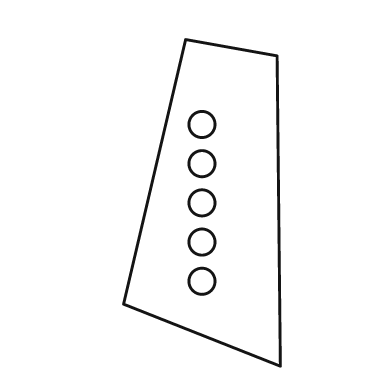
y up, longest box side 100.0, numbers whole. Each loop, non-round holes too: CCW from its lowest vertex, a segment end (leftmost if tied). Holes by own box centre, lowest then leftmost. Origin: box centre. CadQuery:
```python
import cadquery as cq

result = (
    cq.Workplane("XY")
    .moveTo(24.0, -50.0)
    .lineTo(23.0, 45.0)
    .lineTo(-5.0, 50.0)
    .lineTo(-24.0, -31.0)
    .close()
    .moveTo(0.0, -24.0)
    .circle(4.0)
    .moveTo(0.0, -12.0)
    .circle(4.0)
    .moveTo(0.0, 0.0)
    .circle(4.0)
    .moveTo(0.0, 12.0)
    .circle(4.0)
    .moveTo(0.0, 24.0)
    .circle(4.0)
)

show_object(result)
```